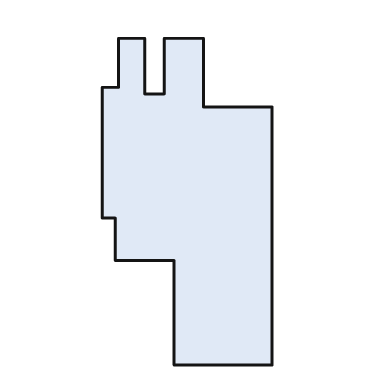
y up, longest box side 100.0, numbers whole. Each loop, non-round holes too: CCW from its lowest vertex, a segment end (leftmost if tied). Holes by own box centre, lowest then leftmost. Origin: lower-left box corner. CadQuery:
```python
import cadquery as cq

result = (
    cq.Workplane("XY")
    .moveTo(22.0, 0.0)
    .lineTo(52.0, 0.0)
    .lineTo(52.0, 79.0)
    .lineTo(31.0, 79.0)
    .lineTo(31.0, 100.0)
    .lineTo(19.0, 100.0)
    .lineTo(19.0, 83.0)
    .lineTo(13.0, 83.0)
    .lineTo(13.0, 100.0)
    .lineTo(5.0, 100.0)
    .lineTo(5.0, 85.0)
    .lineTo(0.0, 85.0)
    .lineTo(0.0, 45.0)
    .lineTo(4.0, 45.0)
    .lineTo(4.0, 32.0)
    .lineTo(22.0, 32.0)
    .close()
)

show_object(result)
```